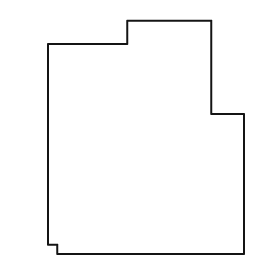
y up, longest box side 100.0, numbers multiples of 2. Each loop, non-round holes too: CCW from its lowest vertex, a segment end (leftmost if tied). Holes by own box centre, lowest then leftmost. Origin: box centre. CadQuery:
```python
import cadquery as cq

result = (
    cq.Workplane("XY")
    .moveTo(-38.0, -50.0)
    .lineTo(42.0, -50.0)
    .lineTo(42.0, 10.0)
    .lineTo(28.0, 10.0)
    .lineTo(28.0, 50.0)
    .lineTo(-8.0, 50.0)
    .lineTo(-8.0, 40.0)
    .lineTo(-42.0, 40.0)
    .lineTo(-42.0, -46.0)
    .lineTo(-38.0, -46.0)
    .close()
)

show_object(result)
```